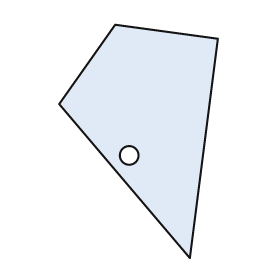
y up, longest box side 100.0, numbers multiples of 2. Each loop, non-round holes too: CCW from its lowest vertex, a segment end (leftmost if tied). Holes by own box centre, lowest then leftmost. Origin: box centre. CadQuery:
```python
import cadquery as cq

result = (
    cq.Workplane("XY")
    .moveTo(22.0, -50.0)
    .lineTo(34.0, 44.0)
    .lineTo(-10.0, 50.0)
    .lineTo(-34.0, 16.0)
    .close()
    .moveTo(-4.0, -6.0)
    .circle(4.0)
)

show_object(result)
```